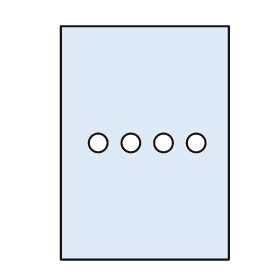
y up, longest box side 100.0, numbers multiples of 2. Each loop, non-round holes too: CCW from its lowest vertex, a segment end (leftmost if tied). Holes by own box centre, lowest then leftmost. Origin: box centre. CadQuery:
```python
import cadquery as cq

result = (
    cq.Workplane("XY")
    .moveTo(-36.0, -50.0)
    .lineTo(36.0, -50.0)
    .lineTo(36.0, 50.0)
    .lineTo(-36.0, 50.0)
    .close()
    .moveTo(-20.0, 0.0)
    .circle(4.0)
    .moveTo(-6.0, 0.0)
    .circle(4.0)
    .moveTo(8.0, 0.0)
    .circle(4.0)
    .moveTo(22.0, 0.0)
    .circle(4.0)
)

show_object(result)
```